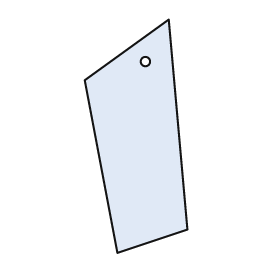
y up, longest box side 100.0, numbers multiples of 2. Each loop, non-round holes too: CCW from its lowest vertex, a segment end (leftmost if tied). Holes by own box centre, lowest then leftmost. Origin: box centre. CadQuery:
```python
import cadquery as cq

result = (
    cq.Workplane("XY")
    .moveTo(-8.0, -50.0)
    .lineTo(22.0, -40.0)
    .lineTo(14.0, 50.0)
    .lineTo(-22.0, 24.0)
    .close()
    .moveTo(4.0, 32.0)
    .circle(2.0)
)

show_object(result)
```